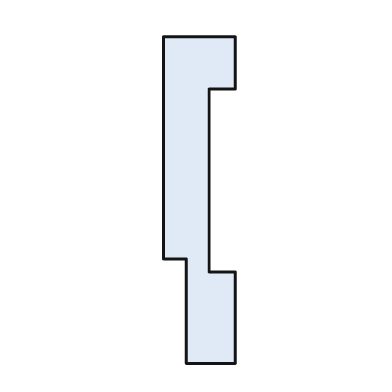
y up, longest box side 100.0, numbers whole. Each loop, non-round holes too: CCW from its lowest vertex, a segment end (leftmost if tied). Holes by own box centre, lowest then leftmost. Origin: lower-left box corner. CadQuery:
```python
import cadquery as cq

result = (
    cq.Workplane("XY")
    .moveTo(7.0, 0.0)
    .lineTo(22.0, 0.0)
    .lineTo(22.0, 28.0)
    .lineTo(14.0, 28.0)
    .lineTo(14.0, 84.0)
    .lineTo(22.0, 84.0)
    .lineTo(22.0, 100.0)
    .lineTo(0.0, 100.0)
    .lineTo(0.0, 32.0)
    .lineTo(7.0, 32.0)
    .close()
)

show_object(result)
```